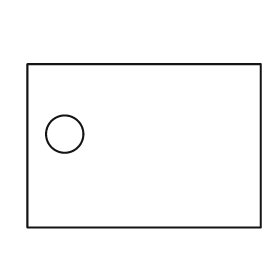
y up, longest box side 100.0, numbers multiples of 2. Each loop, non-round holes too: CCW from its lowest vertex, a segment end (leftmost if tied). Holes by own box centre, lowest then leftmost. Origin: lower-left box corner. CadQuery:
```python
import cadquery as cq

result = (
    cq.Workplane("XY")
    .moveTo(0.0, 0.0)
    .lineTo(100.0, 0.0)
    .lineTo(100.0, 70.0)
    .lineTo(0.0, 70.0)
    .close()
    .moveTo(16.0, 40.0)
    .circle(8.0)
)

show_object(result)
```